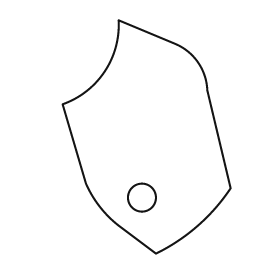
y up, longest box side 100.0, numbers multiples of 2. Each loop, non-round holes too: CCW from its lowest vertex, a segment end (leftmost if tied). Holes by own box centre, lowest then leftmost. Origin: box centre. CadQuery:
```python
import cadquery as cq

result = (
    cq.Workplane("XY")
    .moveTo(4.0, -50.0)
    .threePointArc((22.0, -38.0), (36.0, -22.0))
    .lineTo(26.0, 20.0)
    .threePointArc((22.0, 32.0), (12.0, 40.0))
    .lineTo(-12.0, 50.0)
    .threePointArc((-18.0, 28.0), (-36.0, 14.0))
    .lineTo(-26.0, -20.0)
    .threePointArc((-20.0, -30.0), (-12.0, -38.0))
    .close()
    .moveTo(-2.0, -26.0)
    .circle(6.0)
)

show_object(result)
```